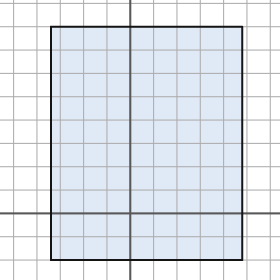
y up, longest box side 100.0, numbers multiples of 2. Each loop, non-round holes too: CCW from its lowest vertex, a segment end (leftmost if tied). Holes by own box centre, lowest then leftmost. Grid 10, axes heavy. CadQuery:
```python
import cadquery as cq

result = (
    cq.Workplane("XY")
    .moveTo(-34.0, -20.0)
    .lineTo(48.0, -20.0)
    .lineTo(48.0, 80.0)
    .lineTo(-34.0, 80.0)
    .close()
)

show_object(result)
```